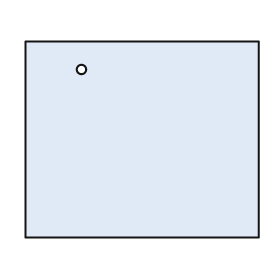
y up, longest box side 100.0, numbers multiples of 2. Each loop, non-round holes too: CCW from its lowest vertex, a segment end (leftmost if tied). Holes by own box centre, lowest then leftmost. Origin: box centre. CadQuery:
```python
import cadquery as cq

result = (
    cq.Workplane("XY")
    .moveTo(-50.0, -42.0)
    .lineTo(50.0, -42.0)
    .lineTo(50.0, 42.0)
    .lineTo(-50.0, 42.0)
    .close()
    .moveTo(-26.0, 30.0)
    .circle(2.0)
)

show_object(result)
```